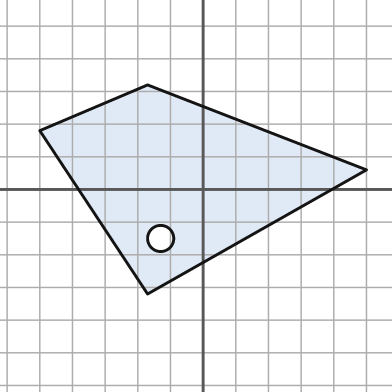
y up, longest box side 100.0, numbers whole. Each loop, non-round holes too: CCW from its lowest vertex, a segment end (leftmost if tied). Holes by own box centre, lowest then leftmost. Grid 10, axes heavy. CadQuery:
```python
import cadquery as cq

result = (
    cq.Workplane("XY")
    .moveTo(-17.0, -32.0)
    .lineTo(50.0, 6.0)
    .lineTo(-17.0, 32.0)
    .lineTo(-50.0, 18.0)
    .close()
    .moveTo(-13.0, -15.0)
    .circle(4.0)
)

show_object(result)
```